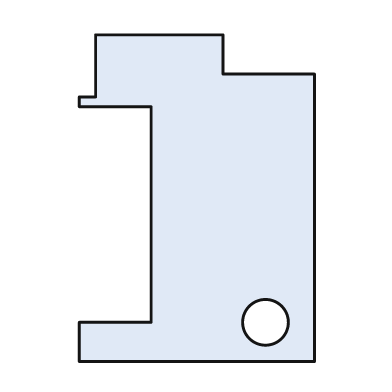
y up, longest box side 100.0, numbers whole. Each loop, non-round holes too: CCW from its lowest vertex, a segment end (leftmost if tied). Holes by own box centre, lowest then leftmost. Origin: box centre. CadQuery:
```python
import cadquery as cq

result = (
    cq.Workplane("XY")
    .moveTo(-36.0, -50.0)
    .lineTo(36.0, -50.0)
    .lineTo(36.0, 38.0)
    .lineTo(8.0, 38.0)
    .lineTo(8.0, 50.0)
    .lineTo(-31.0, 50.0)
    .lineTo(-31.0, 31.0)
    .lineTo(-36.0, 31.0)
    .lineTo(-36.0, 28.0)
    .lineTo(-14.0, 28.0)
    .lineTo(-14.0, -38.0)
    .lineTo(-36.0, -38.0)
    .close()
    .moveTo(21.0, -38.0)
    .circle(7.0)
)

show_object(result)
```